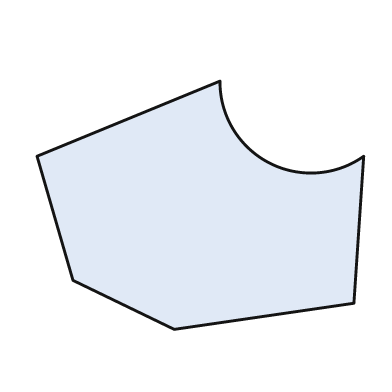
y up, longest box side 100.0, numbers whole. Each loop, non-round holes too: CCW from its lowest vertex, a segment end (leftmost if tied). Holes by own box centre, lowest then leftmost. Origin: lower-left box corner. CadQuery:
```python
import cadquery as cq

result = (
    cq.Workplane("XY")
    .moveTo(42.0, 0.0)
    .lineTo(97.0, 8.0)
    .lineTo(100.0, 53.0)
    .threePointArc((71.0, 51.0), (56.0, 76.0))
    .lineTo(0.0, 53.0)
    .lineTo(11.0, 15.0)
    .close()
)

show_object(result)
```